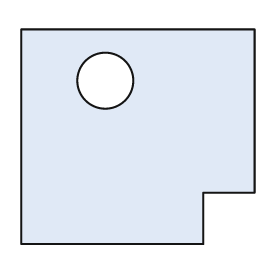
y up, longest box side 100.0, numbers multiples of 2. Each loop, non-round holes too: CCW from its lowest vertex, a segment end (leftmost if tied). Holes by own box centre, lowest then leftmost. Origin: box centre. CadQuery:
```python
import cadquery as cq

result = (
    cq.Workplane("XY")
    .moveTo(-50.0, -46.0)
    .lineTo(28.0, -46.0)
    .lineTo(28.0, -24.0)
    .lineTo(50.0, -24.0)
    .lineTo(50.0, 46.0)
    .lineTo(-50.0, 46.0)
    .close()
    .moveTo(-14.0, 24.0)
    .circle(12.0)
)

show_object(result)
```